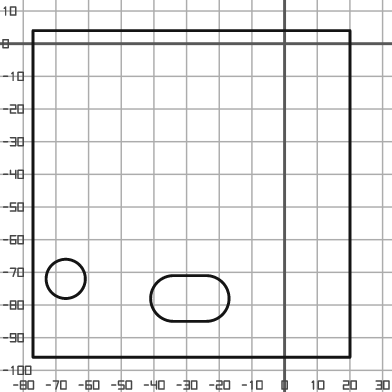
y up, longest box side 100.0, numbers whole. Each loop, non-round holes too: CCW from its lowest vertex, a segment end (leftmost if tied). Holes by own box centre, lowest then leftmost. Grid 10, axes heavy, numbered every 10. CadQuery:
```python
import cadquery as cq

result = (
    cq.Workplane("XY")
    .moveTo(-77.0, -96.0)
    .lineTo(20.0, -96.0)
    .lineTo(20.0, 4.0)
    .lineTo(-77.0, 4.0)
    .close()
    .moveTo(-34.0, -85.0)
    .lineTo(-24.0, -85.0)
    .threePointArc((-17.0, -78.0), (-24.0, -71.0))
    .lineTo(-34.0, -71.0)
    .threePointArc((-41.0, -78.0), (-34.0, -85.0))
    .close()
    .moveTo(-67.0, -72.0)
    .circle(6.0)
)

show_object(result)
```